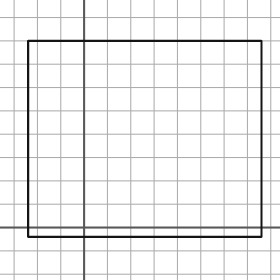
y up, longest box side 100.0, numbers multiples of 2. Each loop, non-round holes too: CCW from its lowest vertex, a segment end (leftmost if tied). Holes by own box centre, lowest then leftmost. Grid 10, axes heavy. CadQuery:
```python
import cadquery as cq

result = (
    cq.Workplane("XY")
    .moveTo(-24.0, -4.0)
    .lineTo(76.0, -4.0)
    .lineTo(76.0, 80.0)
    .lineTo(-24.0, 80.0)
    .close()
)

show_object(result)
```